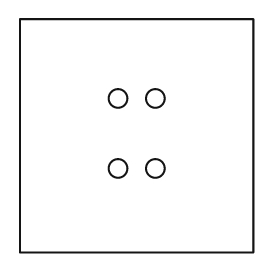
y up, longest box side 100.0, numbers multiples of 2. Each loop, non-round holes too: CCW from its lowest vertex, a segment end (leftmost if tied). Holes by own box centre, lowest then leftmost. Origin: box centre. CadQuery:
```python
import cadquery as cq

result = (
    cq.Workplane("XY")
    .moveTo(-50.0, -50.0)
    .lineTo(50.0, -50.0)
    .lineTo(50.0, 50.0)
    .lineTo(-50.0, 50.0)
    .close()
    .moveTo(-8.0, -14.0)
    .circle(4.0)
    .moveTo(8.0, -14.0)
    .circle(4.0)
    .moveTo(-8.0, 16.0)
    .circle(4.0)
    .moveTo(8.0, 16.0)
    .circle(4.0)
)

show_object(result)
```